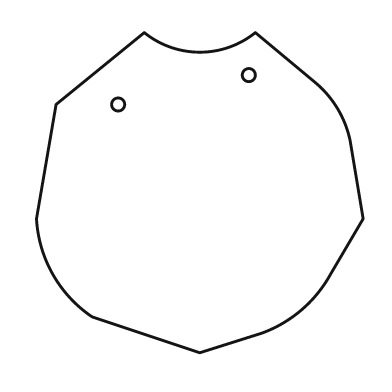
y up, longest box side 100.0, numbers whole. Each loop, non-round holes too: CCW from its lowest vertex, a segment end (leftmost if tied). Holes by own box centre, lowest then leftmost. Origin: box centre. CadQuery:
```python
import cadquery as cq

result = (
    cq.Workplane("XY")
    .moveTo(0.0, -49.0)
    .lineTo(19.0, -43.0)
    .threePointArc((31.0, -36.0), (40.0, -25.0))
    .lineTo(50.0, -8.0)
    .lineTo(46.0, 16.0)
    .threePointArc((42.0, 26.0), (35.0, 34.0))
    .lineTo(17.0, 49.0)
    .threePointArc((0.0, 43.0), (-17.0, 49.0))
    .lineTo(-44.0, 27.0)
    .lineTo(-50.0, -8.0)
    .threePointArc((-45.0, -25.0), (-33.0, -38.0))
    .close()
    .moveTo(-25.0, 27.0)
    .circle(2.0)
    .moveTo(15.0, 36.0)
    .circle(2.0)
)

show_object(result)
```